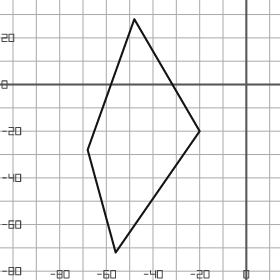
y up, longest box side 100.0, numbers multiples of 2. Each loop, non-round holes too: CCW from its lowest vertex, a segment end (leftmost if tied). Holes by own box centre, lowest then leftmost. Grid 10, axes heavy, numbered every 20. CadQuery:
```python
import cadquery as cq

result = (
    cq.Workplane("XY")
    .moveTo(-56.0, -72.0)
    .lineTo(-20.0, -20.0)
    .lineTo(-48.0, 28.0)
    .lineTo(-68.0, -28.0)
    .close()
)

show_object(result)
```